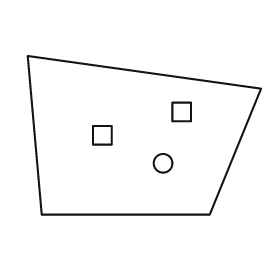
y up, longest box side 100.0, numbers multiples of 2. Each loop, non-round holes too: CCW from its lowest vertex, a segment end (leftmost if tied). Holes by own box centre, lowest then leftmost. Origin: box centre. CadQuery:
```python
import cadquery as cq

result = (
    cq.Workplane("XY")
    .moveTo(-44.0, -34.0)
    .lineTo(28.0, -34.0)
    .lineTo(50.0, 20.0)
    .lineTo(-50.0, 34.0)
    .close()
    .moveTo(8.0, -12.0)
    .circle(4.0)
    .moveTo(-22.0, -4.0)
    .lineTo(-14.0, -4.0)
    .lineTo(-14.0, 4.0)
    .lineTo(-22.0, 4.0)
    .close()
    .moveTo(12.0, 6.0)
    .lineTo(20.0, 6.0)
    .lineTo(20.0, 14.0)
    .lineTo(12.0, 14.0)
    .close()
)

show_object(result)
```